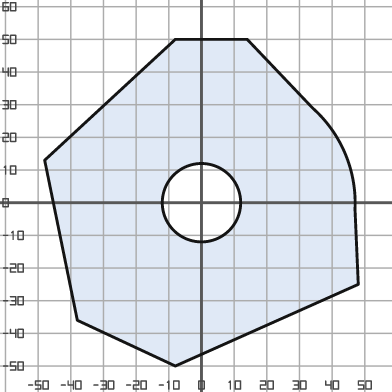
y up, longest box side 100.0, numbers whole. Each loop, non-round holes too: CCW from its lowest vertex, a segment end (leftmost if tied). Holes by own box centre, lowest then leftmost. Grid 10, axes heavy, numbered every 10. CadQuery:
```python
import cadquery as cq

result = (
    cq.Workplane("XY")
    .moveTo(-8.0, -50.0)
    .lineTo(48.0, -25.0)
    .lineTo(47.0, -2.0)
    .threePointArc((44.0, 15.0), (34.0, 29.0))
    .lineTo(14.0, 50.0)
    .lineTo(-8.0, 50.0)
    .lineTo(-48.0, 13.0)
    .lineTo(-38.0, -36.0)
    .close()
    .moveTo(0.0, 0.0)
    .circle(12.0)
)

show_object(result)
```